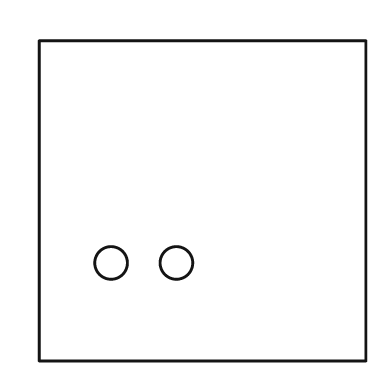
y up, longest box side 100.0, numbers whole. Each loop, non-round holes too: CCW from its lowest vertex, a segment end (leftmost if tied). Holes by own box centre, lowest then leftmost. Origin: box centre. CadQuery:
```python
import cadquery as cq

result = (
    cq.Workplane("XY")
    .moveTo(-50.0, -49.0)
    .lineTo(50.0, -49.0)
    .lineTo(50.0, 49.0)
    .lineTo(-50.0, 49.0)
    .close()
    .moveTo(-28.0, -19.0)
    .circle(5.0)
    .moveTo(-8.0, -19.0)
    .circle(5.0)
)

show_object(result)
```